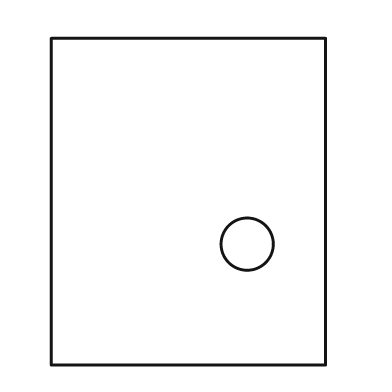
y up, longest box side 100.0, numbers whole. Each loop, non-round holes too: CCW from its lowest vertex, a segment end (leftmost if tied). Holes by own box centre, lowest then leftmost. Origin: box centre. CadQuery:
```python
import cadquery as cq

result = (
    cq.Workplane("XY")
    .moveTo(-42.0, -50.0)
    .lineTo(42.0, -50.0)
    .lineTo(42.0, 50.0)
    .lineTo(-42.0, 50.0)
    .close()
    .moveTo(18.0, -13.0)
    .circle(8.0)
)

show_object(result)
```